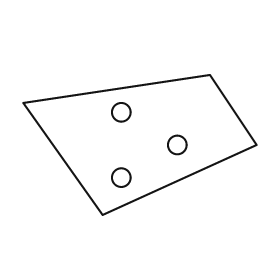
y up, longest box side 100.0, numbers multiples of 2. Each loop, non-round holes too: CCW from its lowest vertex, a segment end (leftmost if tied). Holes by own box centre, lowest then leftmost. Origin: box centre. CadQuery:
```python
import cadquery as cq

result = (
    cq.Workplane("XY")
    .moveTo(-16.0, -30.0)
    .lineTo(50.0, 0.0)
    .lineTo(30.0, 30.0)
    .lineTo(-50.0, 18.0)
    .close()
    .moveTo(-8.0, -14.0)
    .circle(4.0)
    .moveTo(16.0, 0.0)
    .circle(4.0)
    .moveTo(-8.0, 14.0)
    .circle(4.0)
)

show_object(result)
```